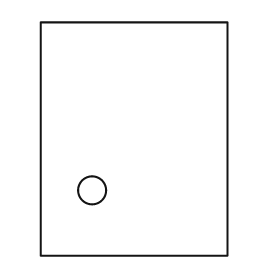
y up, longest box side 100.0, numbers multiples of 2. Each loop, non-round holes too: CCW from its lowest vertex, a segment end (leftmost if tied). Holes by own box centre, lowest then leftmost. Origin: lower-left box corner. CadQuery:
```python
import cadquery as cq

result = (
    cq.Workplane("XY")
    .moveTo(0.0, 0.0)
    .lineTo(80.0, 0.0)
    .lineTo(80.0, 100.0)
    .lineTo(0.0, 100.0)
    .close()
    .moveTo(22.0, 28.0)
    .circle(6.0)
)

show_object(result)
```